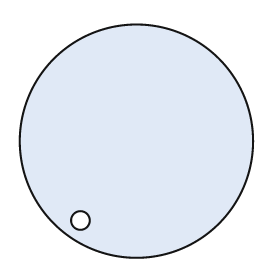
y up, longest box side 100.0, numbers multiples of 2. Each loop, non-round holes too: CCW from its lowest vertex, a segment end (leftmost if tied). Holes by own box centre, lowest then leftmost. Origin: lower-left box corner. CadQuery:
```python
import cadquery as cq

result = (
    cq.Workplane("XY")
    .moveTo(50.0, 50.0)
    .circle(50.0)
    .moveTo(26.0, 16.0)
    .circle(4.0)
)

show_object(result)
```